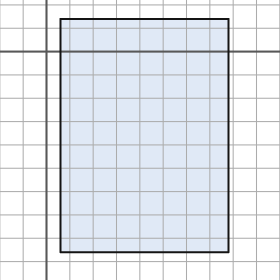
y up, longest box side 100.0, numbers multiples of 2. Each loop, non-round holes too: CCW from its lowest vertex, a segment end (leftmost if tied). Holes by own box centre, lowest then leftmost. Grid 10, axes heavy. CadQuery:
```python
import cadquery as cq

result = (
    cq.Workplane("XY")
    .moveTo(6.0, -86.0)
    .lineTo(78.0, -86.0)
    .lineTo(78.0, 14.0)
    .lineTo(6.0, 14.0)
    .close()
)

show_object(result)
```